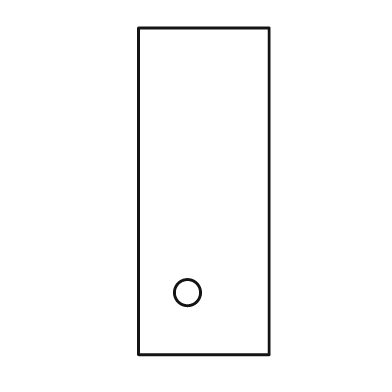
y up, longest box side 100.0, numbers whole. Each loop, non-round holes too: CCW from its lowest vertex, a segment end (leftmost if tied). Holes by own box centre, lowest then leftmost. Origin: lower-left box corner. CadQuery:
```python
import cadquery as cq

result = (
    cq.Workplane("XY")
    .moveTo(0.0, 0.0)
    .lineTo(40.0, 0.0)
    .lineTo(40.0, 100.0)
    .lineTo(0.0, 100.0)
    .close()
    .moveTo(15.0, 19.0)
    .circle(4.0)
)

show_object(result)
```